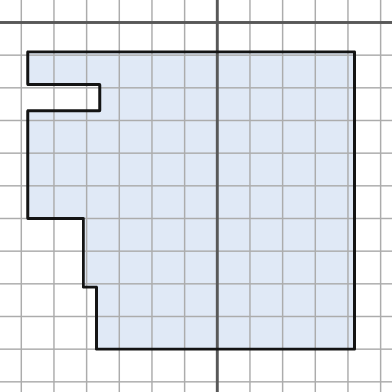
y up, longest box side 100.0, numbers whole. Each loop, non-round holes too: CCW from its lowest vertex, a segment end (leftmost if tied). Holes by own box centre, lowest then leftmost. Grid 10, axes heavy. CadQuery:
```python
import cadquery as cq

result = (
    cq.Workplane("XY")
    .moveTo(-37.0, -100.0)
    .lineTo(42.0, -100.0)
    .lineTo(42.0, -9.0)
    .lineTo(-58.0, -9.0)
    .lineTo(-58.0, -19.0)
    .lineTo(-36.0, -19.0)
    .lineTo(-36.0, -27.0)
    .lineTo(-58.0, -27.0)
    .lineTo(-58.0, -60.0)
    .lineTo(-41.0, -60.0)
    .lineTo(-41.0, -81.0)
    .lineTo(-37.0, -81.0)
    .close()
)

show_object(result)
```